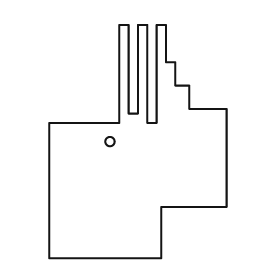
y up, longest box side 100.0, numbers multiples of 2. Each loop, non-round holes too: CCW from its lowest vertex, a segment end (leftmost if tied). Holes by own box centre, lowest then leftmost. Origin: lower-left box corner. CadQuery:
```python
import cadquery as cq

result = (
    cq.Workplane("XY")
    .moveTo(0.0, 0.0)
    .lineTo(48.0, 0.0)
    .lineTo(48.0, 22.0)
    .lineTo(76.0, 22.0)
    .lineTo(76.0, 64.0)
    .lineTo(60.0, 64.0)
    .lineTo(60.0, 74.0)
    .lineTo(54.0, 74.0)
    .lineTo(54.0, 84.0)
    .lineTo(50.0, 84.0)
    .lineTo(50.0, 100.0)
    .lineTo(46.0, 100.0)
    .lineTo(46.0, 58.0)
    .lineTo(42.0, 58.0)
    .lineTo(42.0, 100.0)
    .lineTo(38.0, 100.0)
    .lineTo(38.0, 62.0)
    .lineTo(34.0, 62.0)
    .lineTo(34.0, 100.0)
    .lineTo(30.0, 100.0)
    .lineTo(30.0, 58.0)
    .lineTo(0.0, 58.0)
    .close()
    .moveTo(26.0, 50.0)
    .circle(2.0)
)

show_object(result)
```